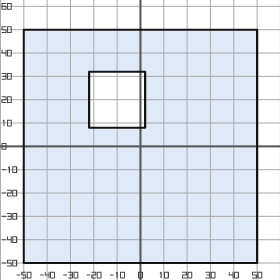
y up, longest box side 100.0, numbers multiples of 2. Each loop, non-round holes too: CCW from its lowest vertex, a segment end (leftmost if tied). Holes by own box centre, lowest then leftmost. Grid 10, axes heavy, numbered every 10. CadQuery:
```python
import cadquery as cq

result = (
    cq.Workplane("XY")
    .moveTo(-50.0, -50.0)
    .lineTo(50.0, -50.0)
    .lineTo(50.0, 50.0)
    .lineTo(-50.0, 50.0)
    .close()
    .moveTo(-22.0, 8.0)
    .lineTo(2.0, 8.0)
    .lineTo(2.0, 32.0)
    .lineTo(-22.0, 32.0)
    .close()
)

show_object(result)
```